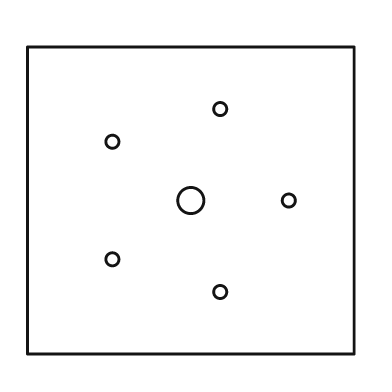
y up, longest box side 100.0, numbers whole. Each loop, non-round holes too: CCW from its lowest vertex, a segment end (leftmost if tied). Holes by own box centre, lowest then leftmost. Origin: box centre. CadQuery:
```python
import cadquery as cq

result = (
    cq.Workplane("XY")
    .moveTo(-50.0, -47.0)
    .lineTo(50.0, -47.0)
    .lineTo(50.0, 47.0)
    .lineTo(-50.0, 47.0)
    .close()
    .moveTo(9.0, -28.0)
    .circle(2.0)
    .moveTo(-24.0, -18.0)
    .circle(2.0)
    .moveTo(0.0, 0.0)
    .circle(4.0)
    .moveTo(30.0, 0.0)
    .circle(2.0)
    .moveTo(-24.0, 18.0)
    .circle(2.0)
    .moveTo(9.0, 28.0)
    .circle(2.0)
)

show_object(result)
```